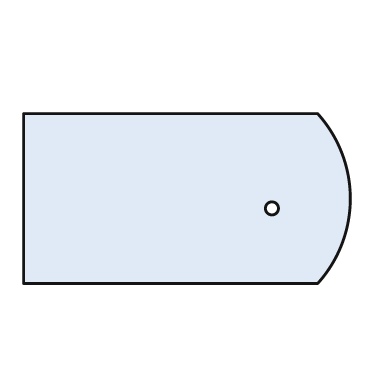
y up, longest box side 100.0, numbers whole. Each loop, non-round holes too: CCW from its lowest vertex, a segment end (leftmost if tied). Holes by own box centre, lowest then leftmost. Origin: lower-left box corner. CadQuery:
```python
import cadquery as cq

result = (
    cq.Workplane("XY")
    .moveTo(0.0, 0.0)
    .lineTo(90.0, 0.0)
    .threePointArc((100.0, 26.0), (90.0, 52.0))
    .lineTo(0.0, 52.0)
    .close()
    .moveTo(76.0, 23.0)
    .circle(2.0)
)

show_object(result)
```